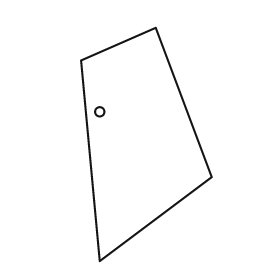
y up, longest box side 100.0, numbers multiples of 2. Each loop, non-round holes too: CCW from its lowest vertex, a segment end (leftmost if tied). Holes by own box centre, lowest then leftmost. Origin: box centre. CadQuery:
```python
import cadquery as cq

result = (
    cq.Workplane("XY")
    .moveTo(-20.0, -50.0)
    .lineTo(28.0, -14.0)
    .lineTo(4.0, 50.0)
    .lineTo(-28.0, 36.0)
    .close()
    .moveTo(-20.0, 14.0)
    .circle(2.0)
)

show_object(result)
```